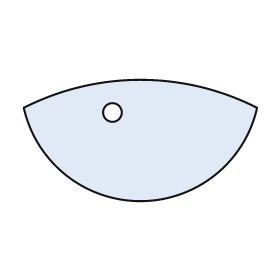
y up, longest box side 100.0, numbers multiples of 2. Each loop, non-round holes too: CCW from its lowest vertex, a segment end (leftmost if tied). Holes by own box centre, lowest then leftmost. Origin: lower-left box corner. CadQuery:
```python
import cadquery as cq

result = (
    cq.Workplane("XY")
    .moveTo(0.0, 40.0)
    .threePointArc((50.0, 0.0), (100.0, 40.0))
    .threePointArc((50.0, 52.0), (0.0, 40.0))
    .close()
    .moveTo(38.0, 38.0)
    .circle(4.0)
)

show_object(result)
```